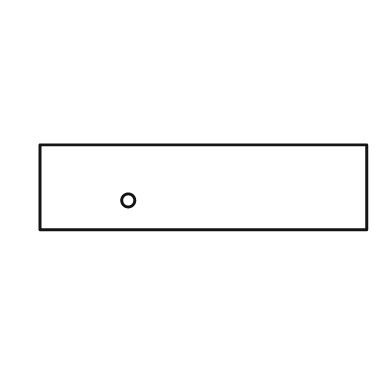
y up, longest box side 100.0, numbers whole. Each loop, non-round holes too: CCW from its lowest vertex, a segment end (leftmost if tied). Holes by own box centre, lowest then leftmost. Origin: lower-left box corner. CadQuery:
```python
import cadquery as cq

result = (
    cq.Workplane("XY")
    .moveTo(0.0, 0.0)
    .lineTo(100.0, 0.0)
    .lineTo(100.0, 26.0)
    .lineTo(0.0, 26.0)
    .close()
    .moveTo(27.0, 9.0)
    .circle(2.0)
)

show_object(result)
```